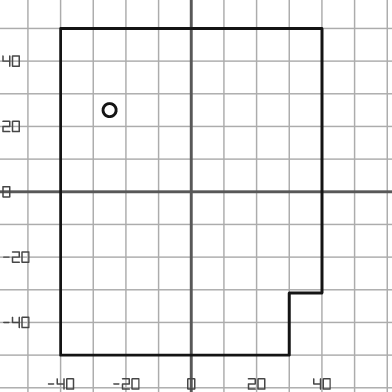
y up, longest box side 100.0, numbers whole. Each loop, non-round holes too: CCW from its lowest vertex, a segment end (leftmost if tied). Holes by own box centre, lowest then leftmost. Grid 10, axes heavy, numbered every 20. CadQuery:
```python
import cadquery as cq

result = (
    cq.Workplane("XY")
    .moveTo(-40.0, -50.0)
    .lineTo(30.0, -50.0)
    .lineTo(30.0, -31.0)
    .lineTo(40.0, -31.0)
    .lineTo(40.0, 50.0)
    .lineTo(-40.0, 50.0)
    .close()
    .moveTo(-25.0, 25.0)
    .circle(2.0)
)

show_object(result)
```